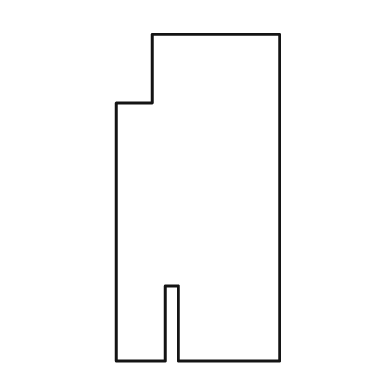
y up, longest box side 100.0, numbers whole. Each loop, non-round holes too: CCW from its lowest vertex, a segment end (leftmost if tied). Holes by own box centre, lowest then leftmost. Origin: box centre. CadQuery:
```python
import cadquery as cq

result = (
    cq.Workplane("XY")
    .moveTo(-25.0, -50.0)
    .lineTo(-10.0, -50.0)
    .lineTo(-10.0, -27.0)
    .lineTo(-6.0, -27.0)
    .lineTo(-6.0, -50.0)
    .lineTo(25.0, -50.0)
    .lineTo(25.0, 50.0)
    .lineTo(-14.0, 50.0)
    .lineTo(-14.0, 29.0)
    .lineTo(-25.0, 29.0)
    .close()
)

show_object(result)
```